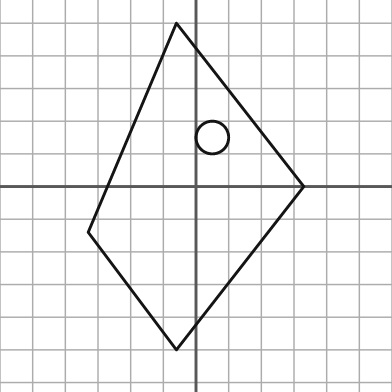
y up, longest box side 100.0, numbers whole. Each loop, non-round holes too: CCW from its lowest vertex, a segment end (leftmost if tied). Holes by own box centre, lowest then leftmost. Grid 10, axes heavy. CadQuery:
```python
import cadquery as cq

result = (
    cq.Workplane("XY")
    .moveTo(-6.0, -50.0)
    .lineTo(33.0, 0.0)
    .lineTo(-6.0, 50.0)
    .lineTo(-33.0, -14.0)
    .close()
    .moveTo(5.0, 15.0)
    .circle(5.0)
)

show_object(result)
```